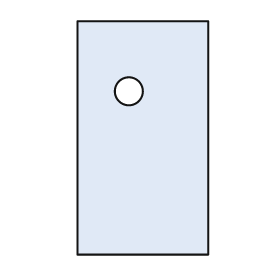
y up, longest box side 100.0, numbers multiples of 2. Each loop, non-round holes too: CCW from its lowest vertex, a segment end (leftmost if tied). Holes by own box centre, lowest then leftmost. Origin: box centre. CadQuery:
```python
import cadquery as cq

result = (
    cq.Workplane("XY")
    .moveTo(-28.0, -50.0)
    .lineTo(28.0, -50.0)
    .lineTo(28.0, 50.0)
    .lineTo(-28.0, 50.0)
    .close()
    .moveTo(-6.0, 20.0)
    .circle(6.0)
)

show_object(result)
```